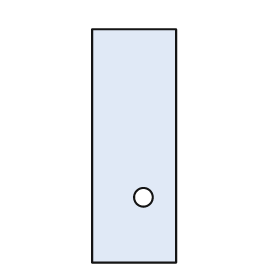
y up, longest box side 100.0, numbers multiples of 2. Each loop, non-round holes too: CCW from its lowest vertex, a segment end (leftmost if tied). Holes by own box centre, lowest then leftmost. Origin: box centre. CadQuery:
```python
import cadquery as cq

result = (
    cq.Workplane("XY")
    .moveTo(-18.0, -50.0)
    .lineTo(18.0, -50.0)
    .lineTo(18.0, 50.0)
    .lineTo(-18.0, 50.0)
    .close()
    .moveTo(4.0, -22.0)
    .circle(4.0)
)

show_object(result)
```